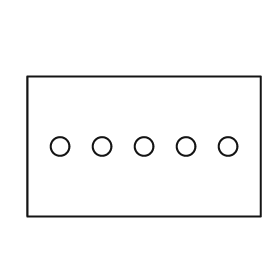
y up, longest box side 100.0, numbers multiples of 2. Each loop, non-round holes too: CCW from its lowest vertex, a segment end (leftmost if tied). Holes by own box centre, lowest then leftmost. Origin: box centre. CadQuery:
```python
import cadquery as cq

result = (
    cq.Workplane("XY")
    .moveTo(-50.0, -30.0)
    .lineTo(50.0, -30.0)
    .lineTo(50.0, 30.0)
    .lineTo(-50.0, 30.0)
    .close()
    .moveTo(-36.0, 0.0)
    .circle(4.0)
    .moveTo(-18.0, 0.0)
    .circle(4.0)
    .moveTo(0.0, 0.0)
    .circle(4.0)
    .moveTo(18.0, 0.0)
    .circle(4.0)
    .moveTo(36.0, 0.0)
    .circle(4.0)
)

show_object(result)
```